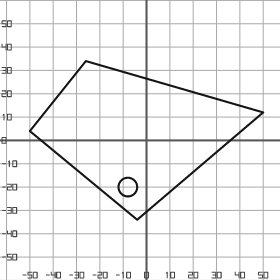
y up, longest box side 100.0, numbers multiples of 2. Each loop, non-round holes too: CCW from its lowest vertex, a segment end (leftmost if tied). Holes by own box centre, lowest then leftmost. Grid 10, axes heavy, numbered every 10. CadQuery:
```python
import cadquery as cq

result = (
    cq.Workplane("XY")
    .moveTo(-4.0, -34.0)
    .lineTo(50.0, 12.0)
    .lineTo(-26.0, 34.0)
    .lineTo(-50.0, 4.0)
    .close()
    .moveTo(-8.0, -20.0)
    .circle(4.0)
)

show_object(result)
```